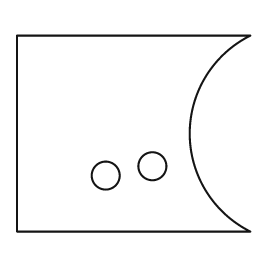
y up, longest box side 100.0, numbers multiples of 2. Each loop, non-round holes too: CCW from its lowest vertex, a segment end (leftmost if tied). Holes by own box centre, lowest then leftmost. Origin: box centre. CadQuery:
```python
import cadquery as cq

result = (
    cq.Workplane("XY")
    .moveTo(-50.0, -42.0)
    .lineTo(50.0, -42.0)
    .threePointArc((24.0, 0.0), (50.0, 42.0))
    .lineTo(-50.0, 42.0)
    .close()
    .moveTo(-12.0, -18.0)
    .circle(6.0)
    .moveTo(8.0, -14.0)
    .circle(6.0)
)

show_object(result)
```